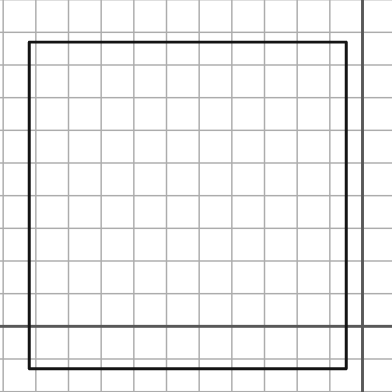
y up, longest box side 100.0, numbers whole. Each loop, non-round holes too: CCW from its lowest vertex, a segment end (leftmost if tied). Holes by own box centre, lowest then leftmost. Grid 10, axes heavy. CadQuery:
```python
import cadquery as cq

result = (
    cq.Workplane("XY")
    .moveTo(-102.0, -13.0)
    .lineTo(-5.0, -13.0)
    .lineTo(-5.0, 87.0)
    .lineTo(-102.0, 87.0)
    .close()
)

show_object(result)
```